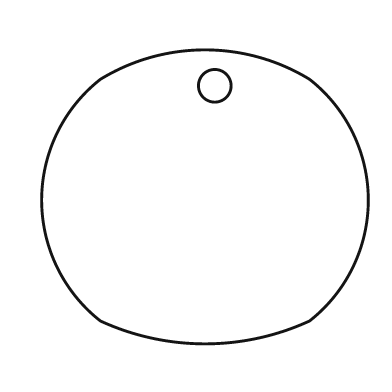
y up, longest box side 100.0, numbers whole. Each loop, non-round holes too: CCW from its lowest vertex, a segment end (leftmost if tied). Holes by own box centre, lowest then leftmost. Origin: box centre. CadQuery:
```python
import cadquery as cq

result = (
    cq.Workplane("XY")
    .moveTo(-32.0, -38.0)
    .threePointArc((0.0, -45.0), (32.0, -38.0))
    .threePointArc((50.0, -1.0), (32.0, 36.0))
    .threePointArc((0.0, 45.0), (-32.0, 36.0))
    .threePointArc((-50.0, -1.0), (-32.0, -38.0))
    .close()
    .moveTo(3.0, 34.0)
    .circle(5.0)
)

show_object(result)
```